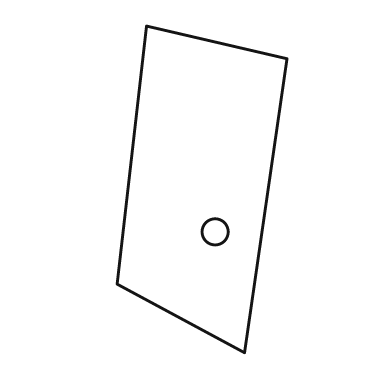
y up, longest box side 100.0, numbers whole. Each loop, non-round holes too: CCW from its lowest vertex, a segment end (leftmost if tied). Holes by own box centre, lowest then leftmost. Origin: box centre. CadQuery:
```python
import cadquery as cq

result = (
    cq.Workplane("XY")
    .moveTo(13.0, -50.0)
    .lineTo(26.0, 40.0)
    .lineTo(-17.0, 50.0)
    .lineTo(-26.0, -29.0)
    .close()
    .moveTo(4.0, -13.0)
    .circle(4.0)
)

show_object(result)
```